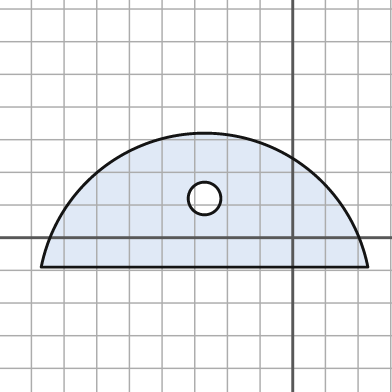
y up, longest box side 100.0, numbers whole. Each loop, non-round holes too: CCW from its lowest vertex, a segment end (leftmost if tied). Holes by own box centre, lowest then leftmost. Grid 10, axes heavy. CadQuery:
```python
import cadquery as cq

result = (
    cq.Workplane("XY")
    .moveTo(-77.0, -9.0)
    .lineTo(23.0, -9.0)
    .threePointArc((-27.0, 32.0), (-77.0, -9.0))
    .close()
    .moveTo(-27.0, 12.0)
    .circle(5.0)
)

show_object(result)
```